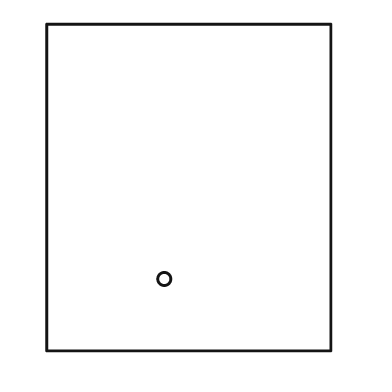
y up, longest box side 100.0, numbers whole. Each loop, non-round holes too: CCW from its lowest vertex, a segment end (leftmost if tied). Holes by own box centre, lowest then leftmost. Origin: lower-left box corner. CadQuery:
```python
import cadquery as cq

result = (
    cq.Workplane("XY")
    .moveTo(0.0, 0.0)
    .lineTo(87.0, 0.0)
    .lineTo(87.0, 100.0)
    .lineTo(0.0, 100.0)
    .close()
    .moveTo(36.0, 22.0)
    .circle(2.0)
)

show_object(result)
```